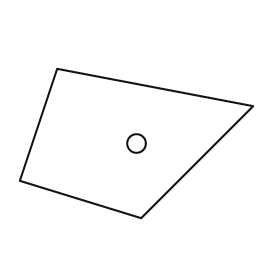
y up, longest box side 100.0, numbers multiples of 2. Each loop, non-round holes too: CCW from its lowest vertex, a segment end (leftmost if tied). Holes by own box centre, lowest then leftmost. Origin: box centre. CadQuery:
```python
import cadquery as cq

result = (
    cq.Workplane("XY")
    .moveTo(2.0, -32.0)
    .lineTo(50.0, 16.0)
    .lineTo(-34.0, 32.0)
    .lineTo(-50.0, -16.0)
    .close()
    .moveTo(0.0, 0.0)
    .circle(4.0)
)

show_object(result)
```